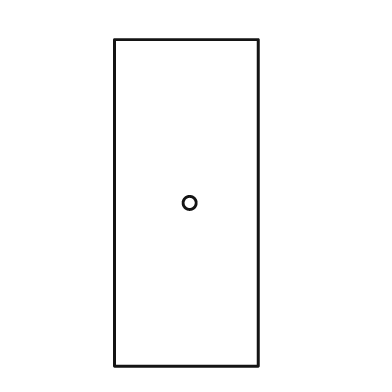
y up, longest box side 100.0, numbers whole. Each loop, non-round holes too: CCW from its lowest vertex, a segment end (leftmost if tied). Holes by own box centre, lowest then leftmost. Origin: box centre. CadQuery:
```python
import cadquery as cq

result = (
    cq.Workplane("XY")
    .moveTo(-22.0, -50.0)
    .lineTo(22.0, -50.0)
    .lineTo(22.0, 50.0)
    .lineTo(-22.0, 50.0)
    .close()
    .moveTo(1.0, 0.0)
    .circle(2.0)
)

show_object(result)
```